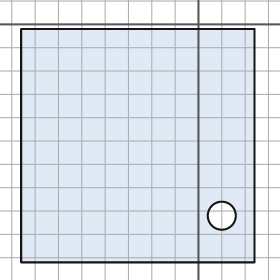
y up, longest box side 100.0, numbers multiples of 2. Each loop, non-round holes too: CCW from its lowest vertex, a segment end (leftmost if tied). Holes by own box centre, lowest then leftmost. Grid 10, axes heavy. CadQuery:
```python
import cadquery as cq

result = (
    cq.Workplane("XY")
    .moveTo(-76.0, -102.0)
    .lineTo(24.0, -102.0)
    .lineTo(24.0, -2.0)
    .lineTo(-76.0, -2.0)
    .close()
    .moveTo(10.0, -82.0)
    .circle(6.0)
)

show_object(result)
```